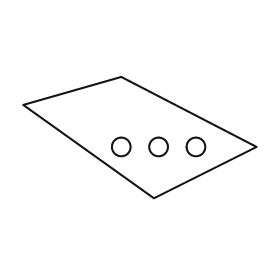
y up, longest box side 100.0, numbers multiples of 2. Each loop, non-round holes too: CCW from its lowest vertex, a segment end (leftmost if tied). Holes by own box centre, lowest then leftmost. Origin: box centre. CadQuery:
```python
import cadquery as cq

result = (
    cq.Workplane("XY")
    .moveTo(6.0, -26.0)
    .lineTo(50.0, -4.0)
    .lineTo(-8.0, 26.0)
    .lineTo(-50.0, 14.0)
    .close()
    .moveTo(-8.0, -4.0)
    .circle(4.0)
    .moveTo(8.0, -4.0)
    .circle(4.0)
    .moveTo(24.0, -4.0)
    .circle(4.0)
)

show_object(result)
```